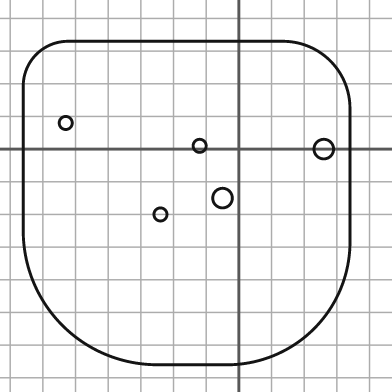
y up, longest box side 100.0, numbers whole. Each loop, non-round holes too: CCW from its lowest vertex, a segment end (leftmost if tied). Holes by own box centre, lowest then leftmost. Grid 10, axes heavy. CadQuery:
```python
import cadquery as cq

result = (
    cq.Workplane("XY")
    .moveTo(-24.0, -66.0)
    .lineTo(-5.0, -66.0)
    .threePointArc((23.0, -55.0), (34.0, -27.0))
    .lineTo(34.0, 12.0)
    .threePointArc((28.0, 27.0), (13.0, 33.0))
    .lineTo(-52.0, 33.0)
    .threePointArc((-62.0, 29.0), (-66.0, 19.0))
    .lineTo(-66.0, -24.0)
    .threePointArc((-54.0, -54.0), (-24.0, -66.0))
    .close()
    .moveTo(-24.0, -20.0)
    .circle(2.0)
    .moveTo(-5.0, -15.0)
    .circle(3.0)
    .moveTo(26.0, 0.0)
    .circle(3.0)
    .moveTo(-12.0, 1.0)
    .circle(2.0)
    .moveTo(-53.0, 8.0)
    .circle(2.0)
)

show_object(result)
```